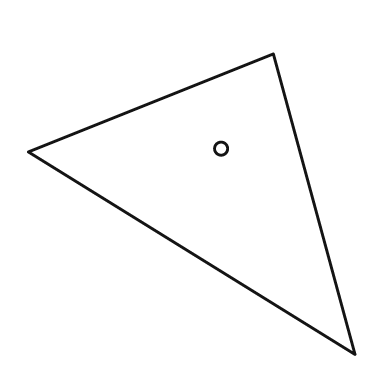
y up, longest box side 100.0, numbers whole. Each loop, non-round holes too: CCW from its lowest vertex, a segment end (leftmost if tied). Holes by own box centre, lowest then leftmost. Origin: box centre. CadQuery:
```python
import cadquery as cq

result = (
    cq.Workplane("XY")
    .moveTo(50.0, -46.0)
    .lineTo(25.0, 46.0)
    .lineTo(-50.0, 16.0)
    .close()
    .moveTo(9.0, 17.0)
    .circle(2.0)
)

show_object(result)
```